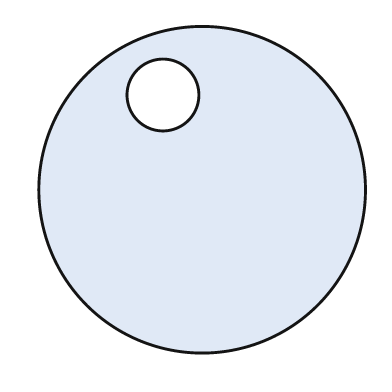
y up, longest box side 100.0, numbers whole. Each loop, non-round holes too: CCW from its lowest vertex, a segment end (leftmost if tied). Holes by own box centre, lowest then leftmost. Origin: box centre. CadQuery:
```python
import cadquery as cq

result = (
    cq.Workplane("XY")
    .moveTo(0.0, 0.0)
    .circle(50.0)
    .moveTo(-12.0, 29.0)
    .circle(11.0)
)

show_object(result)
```